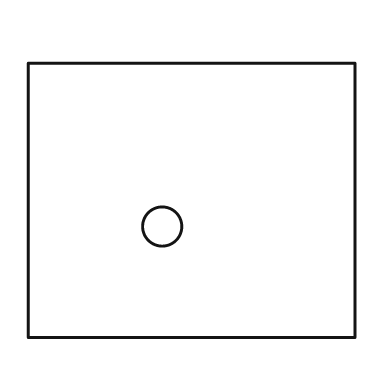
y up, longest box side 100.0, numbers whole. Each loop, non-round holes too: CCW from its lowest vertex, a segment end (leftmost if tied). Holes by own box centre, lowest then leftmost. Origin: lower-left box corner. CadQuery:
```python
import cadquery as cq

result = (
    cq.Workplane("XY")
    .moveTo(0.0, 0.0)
    .lineTo(100.0, 0.0)
    .lineTo(100.0, 84.0)
    .lineTo(0.0, 84.0)
    .close()
    .moveTo(41.0, 34.0)
    .circle(6.0)
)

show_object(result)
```